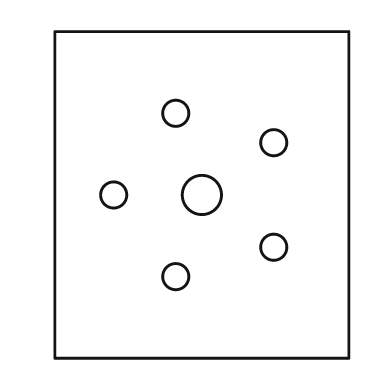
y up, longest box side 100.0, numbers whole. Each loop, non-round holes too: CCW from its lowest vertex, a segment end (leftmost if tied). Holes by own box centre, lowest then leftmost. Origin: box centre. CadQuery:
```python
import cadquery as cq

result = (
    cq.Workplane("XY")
    .moveTo(-45.0, -50.0)
    .lineTo(45.0, -50.0)
    .lineTo(45.0, 50.0)
    .lineTo(-45.0, 50.0)
    .close()
    .moveTo(-8.0, -25.0)
    .circle(4.0)
    .moveTo(22.0, -16.0)
    .circle(4.0)
    .moveTo(-27.0, 0.0)
    .circle(4.0)
    .moveTo(0.0, 0.0)
    .circle(6.0)
    .moveTo(22.0, 16.0)
    .circle(4.0)
    .moveTo(-8.0, 25.0)
    .circle(4.0)
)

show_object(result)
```